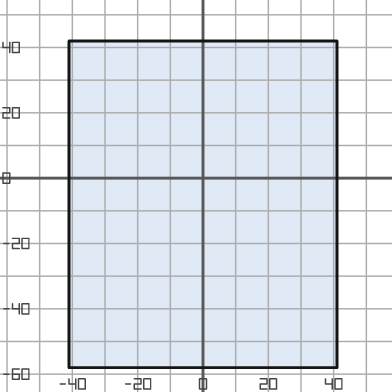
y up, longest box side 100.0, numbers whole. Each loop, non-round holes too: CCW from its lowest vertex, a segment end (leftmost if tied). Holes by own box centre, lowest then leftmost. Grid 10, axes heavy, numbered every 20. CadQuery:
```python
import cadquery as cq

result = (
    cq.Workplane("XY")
    .moveTo(-41.0, -58.0)
    .lineTo(41.0, -58.0)
    .lineTo(41.0, 42.0)
    .lineTo(-41.0, 42.0)
    .close()
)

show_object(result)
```